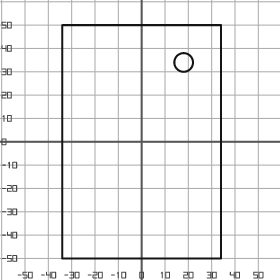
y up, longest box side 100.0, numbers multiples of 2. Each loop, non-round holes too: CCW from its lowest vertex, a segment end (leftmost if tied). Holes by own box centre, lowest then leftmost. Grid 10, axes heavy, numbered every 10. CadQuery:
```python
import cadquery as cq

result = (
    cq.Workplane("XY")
    .moveTo(-34.0, -50.0)
    .lineTo(34.0, -50.0)
    .lineTo(34.0, 50.0)
    .lineTo(-34.0, 50.0)
    .close()
    .moveTo(18.0, 34.0)
    .circle(4.0)
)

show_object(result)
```